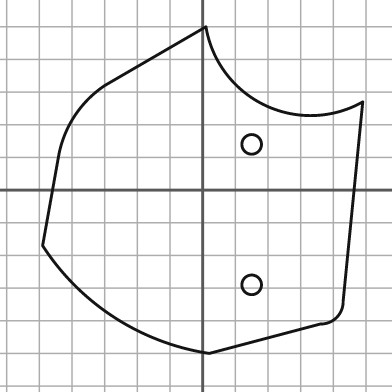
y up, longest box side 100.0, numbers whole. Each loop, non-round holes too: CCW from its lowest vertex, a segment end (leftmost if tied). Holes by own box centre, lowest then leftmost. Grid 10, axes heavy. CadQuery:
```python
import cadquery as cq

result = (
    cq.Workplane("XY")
    .moveTo(2.0, -50.0)
    .lineTo(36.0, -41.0)
    .threePointArc((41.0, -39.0), (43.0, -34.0))
    .lineTo(49.0, 27.0)
    .threePointArc((19.0, 26.0), (1.0, 50.0))
    .lineTo(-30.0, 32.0)
    .threePointArc((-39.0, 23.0), (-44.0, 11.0))
    .lineTo(-49.0, -17.0)
    .threePointArc((-27.0, -39.0), (2.0, -50.0))
    .close()
    .moveTo(15.0, -29.0)
    .circle(3.0)
    .moveTo(15.0, 14.0)
    .circle(3.0)
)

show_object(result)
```